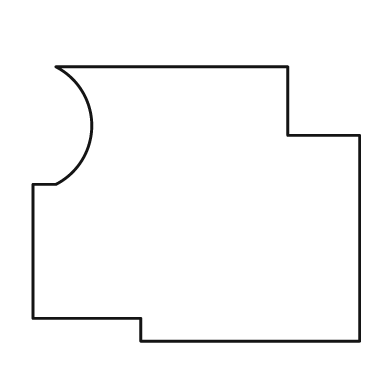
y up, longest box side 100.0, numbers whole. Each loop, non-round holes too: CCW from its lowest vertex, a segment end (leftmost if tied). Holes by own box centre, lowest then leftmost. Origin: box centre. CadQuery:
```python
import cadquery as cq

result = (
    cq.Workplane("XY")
    .moveTo(-17.0, -42.0)
    .lineTo(50.0, -42.0)
    .lineTo(50.0, 21.0)
    .lineTo(28.0, 21.0)
    .lineTo(28.0, 42.0)
    .lineTo(-43.0, 42.0)
    .threePointArc((-32.0, 24.0), (-43.0, 6.0))
    .lineTo(-50.0, 6.0)
    .lineTo(-50.0, -35.0)
    .lineTo(-17.0, -35.0)
    .close()
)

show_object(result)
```